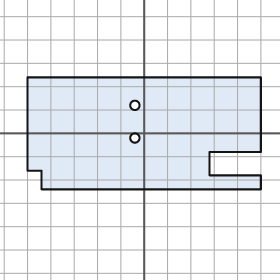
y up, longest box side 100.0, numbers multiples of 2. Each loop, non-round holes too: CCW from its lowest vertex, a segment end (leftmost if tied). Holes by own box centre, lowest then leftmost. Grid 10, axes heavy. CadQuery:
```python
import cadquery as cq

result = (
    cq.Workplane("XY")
    .moveTo(-44.0, -24.0)
    .lineTo(50.0, -24.0)
    .lineTo(50.0, -18.0)
    .lineTo(28.0, -18.0)
    .lineTo(28.0, -8.0)
    .lineTo(50.0, -8.0)
    .lineTo(50.0, 24.0)
    .lineTo(-50.0, 24.0)
    .lineTo(-50.0, -16.0)
    .lineTo(-44.0, -16.0)
    .close()
    .moveTo(-4.0, -2.0)
    .circle(2.0)
    .moveTo(-4.0, 12.0)
    .circle(2.0)
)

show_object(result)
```